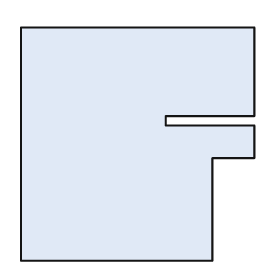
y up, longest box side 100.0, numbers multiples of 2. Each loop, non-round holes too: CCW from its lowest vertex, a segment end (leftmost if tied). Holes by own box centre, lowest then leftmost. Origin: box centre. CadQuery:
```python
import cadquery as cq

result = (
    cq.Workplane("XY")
    .moveTo(-50.0, -50.0)
    .lineTo(32.0, -50.0)
    .lineTo(32.0, -6.0)
    .lineTo(50.0, -6.0)
    .lineTo(50.0, 8.0)
    .lineTo(12.0, 8.0)
    .lineTo(12.0, 12.0)
    .lineTo(50.0, 12.0)
    .lineTo(50.0, 50.0)
    .lineTo(-50.0, 50.0)
    .close()
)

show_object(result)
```